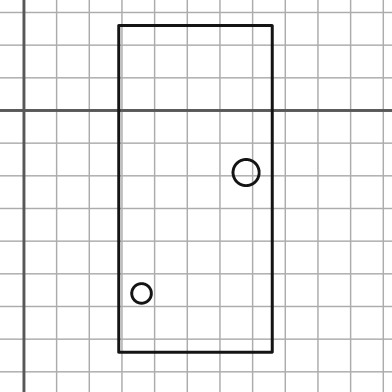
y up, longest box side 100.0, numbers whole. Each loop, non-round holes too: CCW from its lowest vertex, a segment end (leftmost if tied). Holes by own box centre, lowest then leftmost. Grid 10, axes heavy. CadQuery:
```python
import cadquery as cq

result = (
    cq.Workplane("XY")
    .moveTo(29.0, -74.0)
    .lineTo(76.0, -74.0)
    .lineTo(76.0, 26.0)
    .lineTo(29.0, 26.0)
    .close()
    .moveTo(36.0, -56.0)
    .circle(3.0)
    .moveTo(68.0, -19.0)
    .circle(4.0)
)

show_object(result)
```